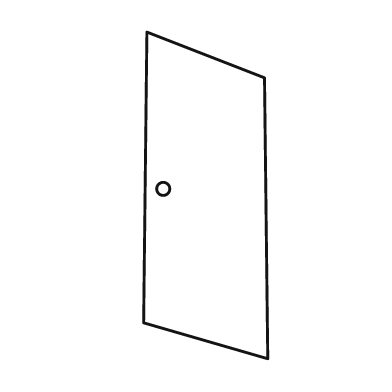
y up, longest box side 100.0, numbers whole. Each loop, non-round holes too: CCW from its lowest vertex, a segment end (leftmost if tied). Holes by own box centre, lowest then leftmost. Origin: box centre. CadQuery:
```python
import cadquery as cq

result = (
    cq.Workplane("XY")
    .moveTo(19.0, -50.0)
    .lineTo(18.0, 36.0)
    .lineTo(-18.0, 50.0)
    .lineTo(-19.0, -39.0)
    .close()
    .moveTo(-13.0, 2.0)
    .circle(2.0)
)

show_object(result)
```